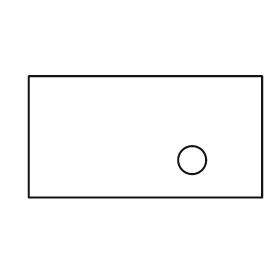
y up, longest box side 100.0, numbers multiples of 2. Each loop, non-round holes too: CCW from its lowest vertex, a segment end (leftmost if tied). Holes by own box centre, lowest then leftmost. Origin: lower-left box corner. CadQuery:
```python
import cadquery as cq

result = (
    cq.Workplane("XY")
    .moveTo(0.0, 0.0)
    .lineTo(100.0, 0.0)
    .lineTo(100.0, 52.0)
    .lineTo(0.0, 52.0)
    .close()
    .moveTo(70.0, 16.0)
    .circle(6.0)
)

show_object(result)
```